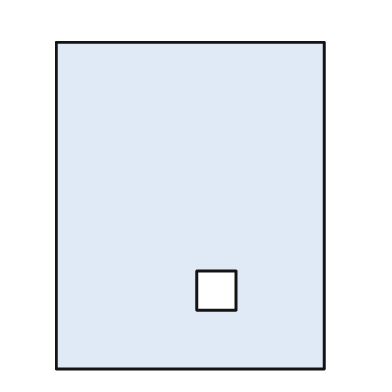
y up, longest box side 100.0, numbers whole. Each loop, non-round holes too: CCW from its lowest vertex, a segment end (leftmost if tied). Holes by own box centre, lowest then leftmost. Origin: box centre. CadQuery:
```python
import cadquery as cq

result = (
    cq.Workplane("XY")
    .moveTo(-41.0, -50.0)
    .lineTo(41.0, -50.0)
    .lineTo(41.0, 50.0)
    .lineTo(-41.0, 50.0)
    .close()
    .moveTo(2.0, -32.0)
    .lineTo(14.0, -32.0)
    .lineTo(14.0, -20.0)
    .lineTo(2.0, -20.0)
    .close()
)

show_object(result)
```